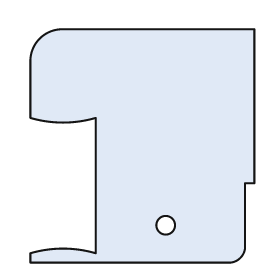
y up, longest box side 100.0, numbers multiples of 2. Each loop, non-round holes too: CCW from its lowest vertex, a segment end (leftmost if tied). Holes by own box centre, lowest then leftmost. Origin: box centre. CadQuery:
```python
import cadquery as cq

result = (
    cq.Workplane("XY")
    .moveTo(-48.0, -50.0)
    .lineTo(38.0, -50.0)
    .threePointArc((42.0, -48.0), (44.0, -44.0))
    .lineTo(44.0, -16.0)
    .lineTo(48.0, -16.0)
    .lineTo(48.0, 50.0)
    .lineTo(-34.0, 50.0)
    .threePointArc((-44.0, 46.0), (-48.0, 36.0))
    .lineTo(-48.0, 12.0)
    .threePointArc((-34.0, 10.0), (-20.0, 12.0))
    .lineTo(-20.0, -46.0)
    .threePointArc((-34.0, -44.0), (-48.0, -46.0))
    .close()
    .moveTo(10.0, -34.0)
    .circle(4.0)
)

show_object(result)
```